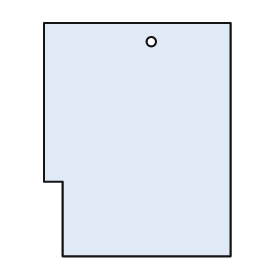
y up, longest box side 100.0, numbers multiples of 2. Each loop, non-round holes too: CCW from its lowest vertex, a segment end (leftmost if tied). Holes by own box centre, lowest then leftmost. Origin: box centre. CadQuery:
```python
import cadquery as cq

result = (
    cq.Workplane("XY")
    .moveTo(-32.0, -50.0)
    .lineTo(40.0, -50.0)
    .lineTo(40.0, 50.0)
    .lineTo(-40.0, 50.0)
    .lineTo(-40.0, -18.0)
    .lineTo(-32.0, -18.0)
    .close()
    .moveTo(6.0, 42.0)
    .circle(2.0)
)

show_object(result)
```